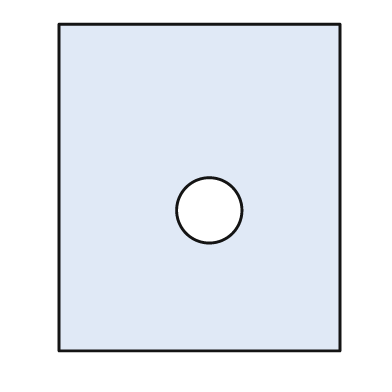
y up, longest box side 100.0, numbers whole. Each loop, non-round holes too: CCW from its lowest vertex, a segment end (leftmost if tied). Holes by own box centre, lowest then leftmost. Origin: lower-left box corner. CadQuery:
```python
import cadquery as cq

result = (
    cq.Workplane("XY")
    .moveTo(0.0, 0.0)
    .lineTo(86.0, 0.0)
    .lineTo(86.0, 100.0)
    .lineTo(0.0, 100.0)
    .close()
    .moveTo(46.0, 43.0)
    .circle(10.0)
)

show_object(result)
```